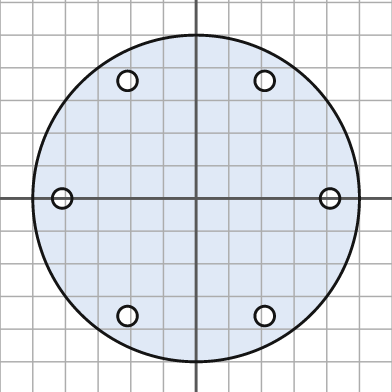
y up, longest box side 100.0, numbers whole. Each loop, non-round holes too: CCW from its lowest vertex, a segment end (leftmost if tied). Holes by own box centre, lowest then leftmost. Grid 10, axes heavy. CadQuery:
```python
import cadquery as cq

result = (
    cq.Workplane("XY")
    .moveTo(0.0, 0.0)
    .circle(50.0)
    .moveTo(-21.0, -36.0)
    .circle(3.0)
    .moveTo(21.0, -36.0)
    .circle(3.0)
    .moveTo(-41.0, 0.0)
    .circle(3.0)
    .moveTo(41.0, 0.0)
    .circle(3.0)
    .moveTo(-21.0, 36.0)
    .circle(3.0)
    .moveTo(21.0, 36.0)
    .circle(3.0)
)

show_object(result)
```